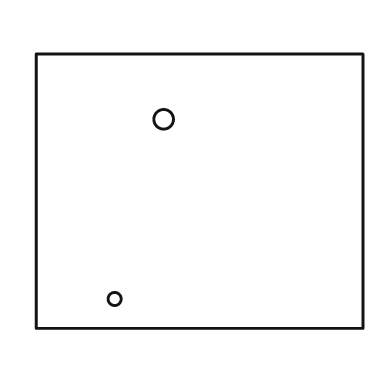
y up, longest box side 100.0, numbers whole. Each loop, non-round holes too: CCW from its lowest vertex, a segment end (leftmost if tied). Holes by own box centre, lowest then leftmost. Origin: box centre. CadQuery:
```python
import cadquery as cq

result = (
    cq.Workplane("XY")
    .moveTo(-50.0, -42.0)
    .lineTo(50.0, -42.0)
    .lineTo(50.0, 42.0)
    .lineTo(-50.0, 42.0)
    .close()
    .moveTo(-26.0, -33.0)
    .circle(2.0)
    .moveTo(-11.0, 22.0)
    .circle(3.0)
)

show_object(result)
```